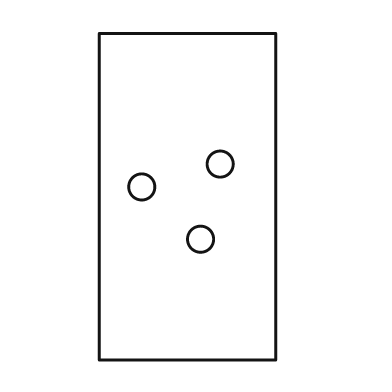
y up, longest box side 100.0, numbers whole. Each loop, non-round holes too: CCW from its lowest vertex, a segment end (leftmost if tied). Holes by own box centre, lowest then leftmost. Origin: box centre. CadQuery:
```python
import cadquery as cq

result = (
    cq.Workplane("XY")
    .moveTo(-27.0, -50.0)
    .lineTo(27.0, -50.0)
    .lineTo(27.0, 50.0)
    .lineTo(-27.0, 50.0)
    .close()
    .moveTo(4.0, -13.0)
    .circle(4.0)
    .moveTo(-14.0, 3.0)
    .circle(4.0)
    .moveTo(10.0, 10.0)
    .circle(4.0)
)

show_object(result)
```